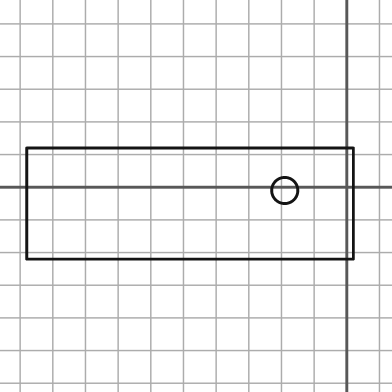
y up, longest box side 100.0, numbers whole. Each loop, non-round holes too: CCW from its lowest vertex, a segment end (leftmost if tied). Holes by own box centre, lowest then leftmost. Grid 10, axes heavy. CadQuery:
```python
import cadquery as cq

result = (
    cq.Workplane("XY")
    .moveTo(-98.0, -22.0)
    .lineTo(2.0, -22.0)
    .lineTo(2.0, 12.0)
    .lineTo(-98.0, 12.0)
    .close()
    .moveTo(-19.0, -1.0)
    .circle(4.0)
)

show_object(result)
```